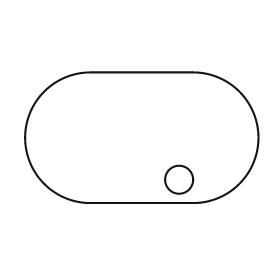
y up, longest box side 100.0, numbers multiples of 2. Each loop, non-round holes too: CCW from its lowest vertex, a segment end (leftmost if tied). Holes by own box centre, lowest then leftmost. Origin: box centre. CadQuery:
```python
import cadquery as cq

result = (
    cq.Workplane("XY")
    .moveTo(-22.0, -28.0)
    .lineTo(22.0, -28.0)
    .threePointArc((50.0, 0.0), (22.0, 28.0))
    .lineTo(-22.0, 28.0)
    .threePointArc((-50.0, 0.0), (-22.0, -28.0))
    .close()
    .moveTo(16.0, -18.0)
    .circle(6.0)
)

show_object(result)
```